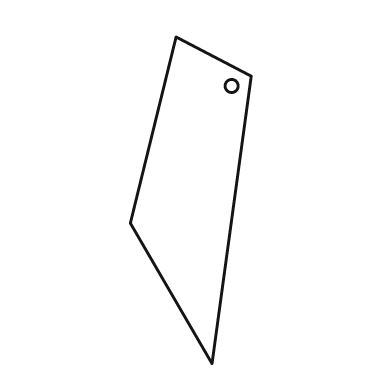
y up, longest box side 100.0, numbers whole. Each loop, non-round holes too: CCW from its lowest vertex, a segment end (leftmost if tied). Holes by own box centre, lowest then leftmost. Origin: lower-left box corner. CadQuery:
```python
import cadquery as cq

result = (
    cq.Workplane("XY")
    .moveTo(25.0, 0.0)
    .lineTo(37.0, 88.0)
    .lineTo(14.0, 100.0)
    .lineTo(0.0, 43.0)
    .close()
    .moveTo(31.0, 85.0)
    .circle(2.0)
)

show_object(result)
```